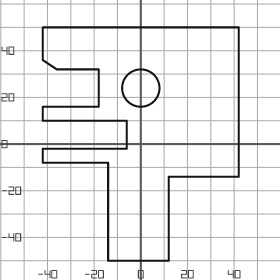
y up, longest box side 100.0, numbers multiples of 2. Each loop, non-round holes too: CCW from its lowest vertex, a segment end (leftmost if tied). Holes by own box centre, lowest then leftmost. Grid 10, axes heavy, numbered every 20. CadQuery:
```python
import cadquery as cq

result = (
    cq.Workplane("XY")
    .moveTo(-14.0, -50.0)
    .lineTo(12.0, -50.0)
    .lineTo(12.0, -14.0)
    .lineTo(42.0, -14.0)
    .lineTo(42.0, 50.0)
    .lineTo(-42.0, 50.0)
    .lineTo(-42.0, 36.0)
    .lineTo(-36.0, 32.0)
    .lineTo(-18.0, 32.0)
    .lineTo(-18.0, 16.0)
    .lineTo(-42.0, 16.0)
    .lineTo(-42.0, 10.0)
    .lineTo(-6.0, 10.0)
    .lineTo(-6.0, -2.0)
    .lineTo(-42.0, -2.0)
    .lineTo(-42.0, -8.0)
    .lineTo(-14.0, -8.0)
    .close()
    .moveTo(0.0, 24.0)
    .circle(8.0)
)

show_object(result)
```